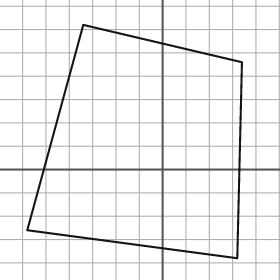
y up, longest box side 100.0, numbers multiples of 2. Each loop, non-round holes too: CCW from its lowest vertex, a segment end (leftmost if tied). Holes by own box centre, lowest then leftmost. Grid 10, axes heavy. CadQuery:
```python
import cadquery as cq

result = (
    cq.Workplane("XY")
    .moveTo(32.0, -38.0)
    .lineTo(34.0, 46.0)
    .lineTo(-34.0, 62.0)
    .lineTo(-58.0, -26.0)
    .close()
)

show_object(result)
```